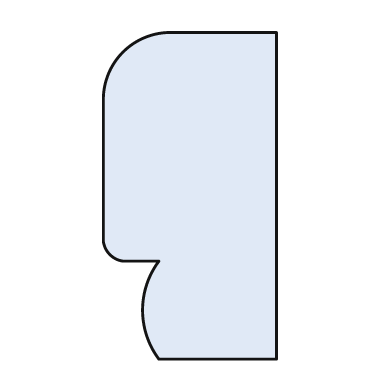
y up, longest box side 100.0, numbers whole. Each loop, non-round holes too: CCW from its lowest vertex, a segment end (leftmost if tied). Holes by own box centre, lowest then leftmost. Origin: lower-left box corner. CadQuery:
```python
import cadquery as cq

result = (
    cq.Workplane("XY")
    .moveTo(17.0, 0.0)
    .lineTo(53.0, 0.0)
    .lineTo(53.0, 100.0)
    .lineTo(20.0, 100.0)
    .threePointArc((6.0, 94.0), (0.0, 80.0))
    .lineTo(0.0, 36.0)
    .threePointArc((2.0, 32.0), (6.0, 30.0))
    .lineTo(17.0, 30.0)
    .threePointArc((12.0, 15.0), (17.0, 0.0))
    .close()
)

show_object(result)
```